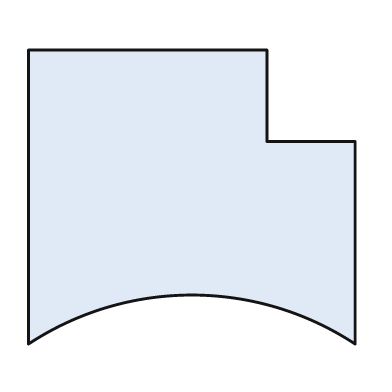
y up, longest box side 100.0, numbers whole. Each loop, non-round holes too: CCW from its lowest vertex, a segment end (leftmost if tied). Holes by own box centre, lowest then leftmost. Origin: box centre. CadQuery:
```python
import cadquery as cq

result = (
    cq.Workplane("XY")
    .moveTo(-50.0, -45.0)
    .threePointArc((0.0, -30.0), (50.0, -45.0))
    .lineTo(50.0, 17.0)
    .lineTo(23.0, 17.0)
    .lineTo(23.0, 45.0)
    .lineTo(-50.0, 45.0)
    .close()
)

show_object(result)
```